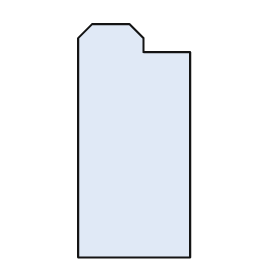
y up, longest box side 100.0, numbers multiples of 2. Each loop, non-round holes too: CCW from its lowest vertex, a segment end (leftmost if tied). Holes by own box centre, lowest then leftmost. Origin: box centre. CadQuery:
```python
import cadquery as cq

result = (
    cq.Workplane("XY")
    .moveTo(-24.0, -50.0)
    .lineTo(24.0, -50.0)
    .lineTo(24.0, 38.0)
    .lineTo(4.0, 38.0)
    .lineTo(4.0, 44.0)
    .lineTo(-2.0, 50.0)
    .lineTo(-18.0, 50.0)
    .lineTo(-24.0, 44.0)
    .close()
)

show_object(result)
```